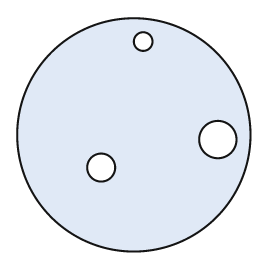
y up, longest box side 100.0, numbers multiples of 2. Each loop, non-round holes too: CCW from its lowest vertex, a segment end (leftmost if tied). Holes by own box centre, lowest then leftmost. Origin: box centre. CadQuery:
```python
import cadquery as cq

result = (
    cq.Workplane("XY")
    .moveTo(0.0, 0.0)
    .circle(50.0)
    .moveTo(-14.0, -14.0)
    .circle(6.0)
    .moveTo(36.0, -2.0)
    .circle(8.0)
    .moveTo(4.0, 40.0)
    .circle(4.0)
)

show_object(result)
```